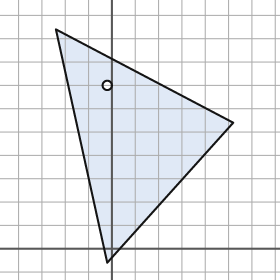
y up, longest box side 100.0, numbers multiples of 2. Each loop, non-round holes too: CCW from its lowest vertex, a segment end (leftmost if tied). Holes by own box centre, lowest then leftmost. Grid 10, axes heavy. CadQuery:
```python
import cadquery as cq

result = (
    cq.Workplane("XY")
    .moveTo(-2.0, -6.0)
    .lineTo(52.0, 54.0)
    .lineTo(-24.0, 94.0)
    .close()
    .moveTo(-2.0, 70.0)
    .circle(2.0)
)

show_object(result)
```